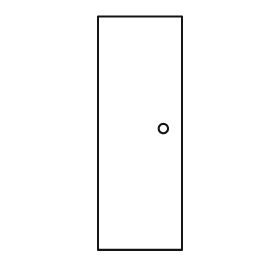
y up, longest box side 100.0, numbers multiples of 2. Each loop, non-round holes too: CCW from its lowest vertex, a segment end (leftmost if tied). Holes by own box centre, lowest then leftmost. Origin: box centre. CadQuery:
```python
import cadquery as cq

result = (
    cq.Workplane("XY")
    .moveTo(-18.0, -50.0)
    .lineTo(18.0, -50.0)
    .lineTo(18.0, 50.0)
    .lineTo(-18.0, 50.0)
    .close()
    .moveTo(10.0, 2.0)
    .circle(2.0)
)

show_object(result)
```